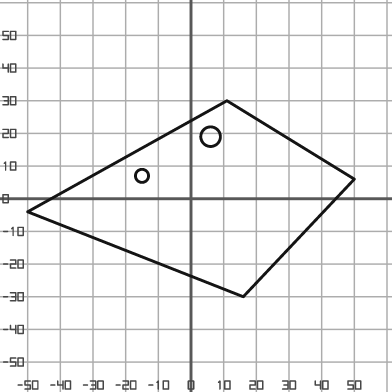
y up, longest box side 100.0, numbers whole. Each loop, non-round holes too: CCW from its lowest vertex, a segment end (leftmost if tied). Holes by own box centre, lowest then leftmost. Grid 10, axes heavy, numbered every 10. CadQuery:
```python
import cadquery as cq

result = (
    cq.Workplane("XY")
    .moveTo(16.0, -30.0)
    .lineTo(50.0, 6.0)
    .lineTo(11.0, 30.0)
    .lineTo(-50.0, -4.0)
    .close()
    .moveTo(-15.0, 7.0)
    .circle(2.0)
    .moveTo(6.0, 19.0)
    .circle(3.0)
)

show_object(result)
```